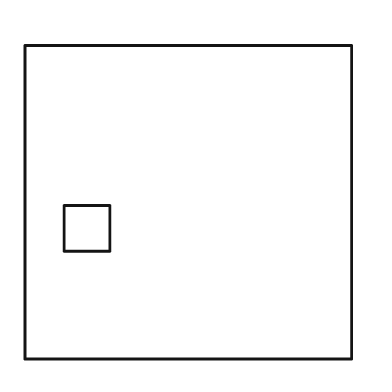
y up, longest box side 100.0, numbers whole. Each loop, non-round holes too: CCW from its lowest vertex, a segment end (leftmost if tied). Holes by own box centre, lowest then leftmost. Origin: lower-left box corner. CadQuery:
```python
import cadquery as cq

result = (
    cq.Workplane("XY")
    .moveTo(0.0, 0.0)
    .lineTo(100.0, 0.0)
    .lineTo(100.0, 96.0)
    .lineTo(0.0, 96.0)
    .close()
    .moveTo(12.0, 33.0)
    .lineTo(26.0, 33.0)
    .lineTo(26.0, 47.0)
    .lineTo(12.0, 47.0)
    .close()
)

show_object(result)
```